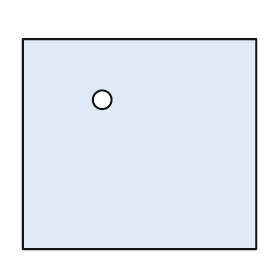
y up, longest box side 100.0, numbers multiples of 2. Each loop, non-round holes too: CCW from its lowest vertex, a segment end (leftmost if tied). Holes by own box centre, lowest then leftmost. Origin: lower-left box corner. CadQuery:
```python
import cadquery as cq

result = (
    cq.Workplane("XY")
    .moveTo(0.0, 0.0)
    .lineTo(100.0, 0.0)
    .lineTo(100.0, 90.0)
    .lineTo(0.0, 90.0)
    .close()
    .moveTo(34.0, 64.0)
    .circle(4.0)
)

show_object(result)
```